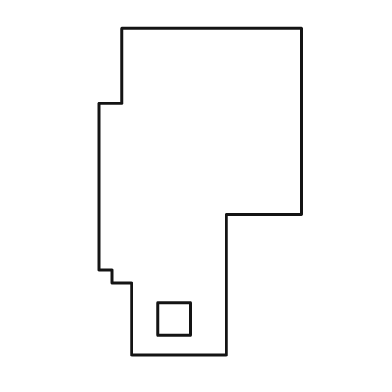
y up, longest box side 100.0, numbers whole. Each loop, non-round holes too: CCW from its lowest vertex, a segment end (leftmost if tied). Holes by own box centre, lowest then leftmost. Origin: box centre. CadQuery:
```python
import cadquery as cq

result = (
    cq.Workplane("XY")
    .moveTo(-21.0, -50.0)
    .lineTo(8.0, -50.0)
    .lineTo(8.0, -7.0)
    .lineTo(31.0, -7.0)
    .lineTo(31.0, 50.0)
    .lineTo(-24.0, 50.0)
    .lineTo(-24.0, 27.0)
    .lineTo(-31.0, 27.0)
    .lineTo(-31.0, -24.0)
    .lineTo(-27.0, -24.0)
    .lineTo(-27.0, -28.0)
    .lineTo(-21.0, -28.0)
    .close()
    .moveTo(-13.0, -44.0)
    .lineTo(-3.0, -44.0)
    .lineTo(-3.0, -34.0)
    .lineTo(-13.0, -34.0)
    .close()
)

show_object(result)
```